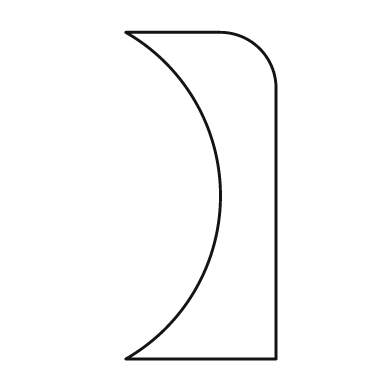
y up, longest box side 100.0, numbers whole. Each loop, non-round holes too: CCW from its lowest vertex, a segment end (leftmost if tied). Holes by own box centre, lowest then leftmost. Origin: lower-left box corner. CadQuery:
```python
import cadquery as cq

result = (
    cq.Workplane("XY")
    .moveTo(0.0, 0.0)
    .lineTo(46.0, 0.0)
    .lineTo(46.0, 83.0)
    .threePointArc((41.0, 95.0), (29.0, 100.0))
    .lineTo(0.0, 100.0)
    .threePointArc((29.0, 50.0), (0.0, 0.0))
    .close()
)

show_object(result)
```